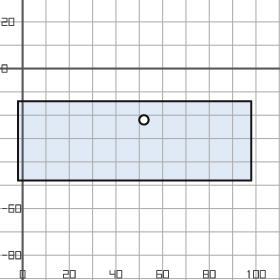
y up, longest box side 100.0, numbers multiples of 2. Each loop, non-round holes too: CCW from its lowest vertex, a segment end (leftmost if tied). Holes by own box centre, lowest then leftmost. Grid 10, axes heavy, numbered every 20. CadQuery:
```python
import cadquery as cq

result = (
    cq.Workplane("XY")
    .moveTo(-2.0, -48.0)
    .lineTo(98.0, -48.0)
    .lineTo(98.0, -14.0)
    .lineTo(-2.0, -14.0)
    .close()
    .moveTo(52.0, -22.0)
    .circle(2.0)
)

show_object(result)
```